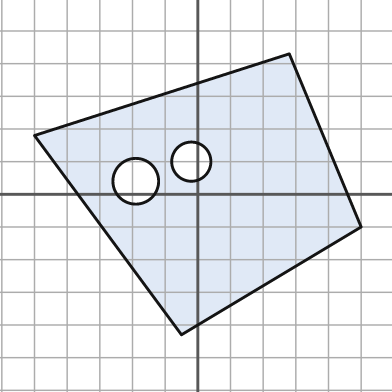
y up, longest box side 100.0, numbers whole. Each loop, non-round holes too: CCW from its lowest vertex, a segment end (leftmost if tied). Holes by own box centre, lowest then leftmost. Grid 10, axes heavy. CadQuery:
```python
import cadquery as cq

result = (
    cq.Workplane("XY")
    .moveTo(-5.0, -43.0)
    .lineTo(50.0, -10.0)
    .lineTo(28.0, 43.0)
    .lineTo(-50.0, 18.0)
    .close()
    .moveTo(-19.0, 4.0)
    .circle(7.0)
    .moveTo(-2.0, 10.0)
    .circle(6.0)
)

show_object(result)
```